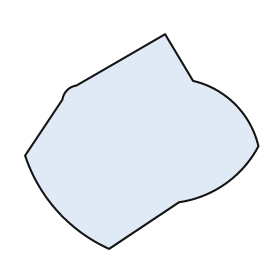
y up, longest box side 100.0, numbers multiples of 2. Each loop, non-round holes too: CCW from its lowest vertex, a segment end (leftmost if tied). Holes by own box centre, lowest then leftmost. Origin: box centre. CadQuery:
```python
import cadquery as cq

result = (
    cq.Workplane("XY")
    .moveTo(-14.0, -46.0)
    .lineTo(16.0, -26.0)
    .threePointArc((36.0, -18.0), (50.0, -2.0))
    .threePointArc((40.0, 16.0), (22.0, 26.0))
    .lineTo(10.0, 46.0)
    .lineTo(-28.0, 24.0)
    .threePointArc((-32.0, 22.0), (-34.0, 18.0))
    .lineTo(-50.0, -6.0)
    .threePointArc((-36.0, -30.0), (-14.0, -46.0))
    .close()
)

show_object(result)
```